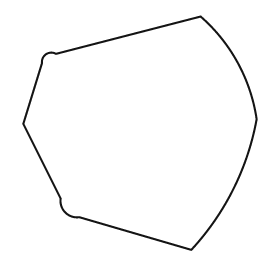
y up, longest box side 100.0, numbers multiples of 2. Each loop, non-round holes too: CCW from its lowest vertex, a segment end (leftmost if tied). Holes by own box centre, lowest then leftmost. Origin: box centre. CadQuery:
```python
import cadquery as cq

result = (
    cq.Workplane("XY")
    .moveTo(22.0, -50.0)
    .threePointArc((40.0, -24.0), (50.0, 6.0))
    .threePointArc((42.0, 30.0), (26.0, 50.0))
    .lineTo(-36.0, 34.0)
    .threePointArc((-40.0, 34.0), (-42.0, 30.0))
    .lineTo(-50.0, 4.0)
    .lineTo(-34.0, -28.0)
    .threePointArc((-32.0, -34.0), (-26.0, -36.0))
    .close()
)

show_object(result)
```